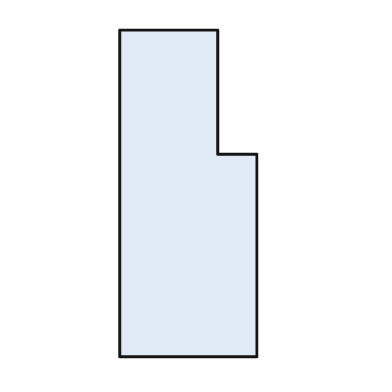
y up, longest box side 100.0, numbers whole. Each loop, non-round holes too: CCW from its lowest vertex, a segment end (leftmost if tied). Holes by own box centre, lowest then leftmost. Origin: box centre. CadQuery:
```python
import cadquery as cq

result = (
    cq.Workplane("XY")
    .moveTo(-21.0, -50.0)
    .lineTo(21.0, -50.0)
    .lineTo(21.0, 12.0)
    .lineTo(9.0, 12.0)
    .lineTo(9.0, 50.0)
    .lineTo(-21.0, 50.0)
    .close()
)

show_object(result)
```